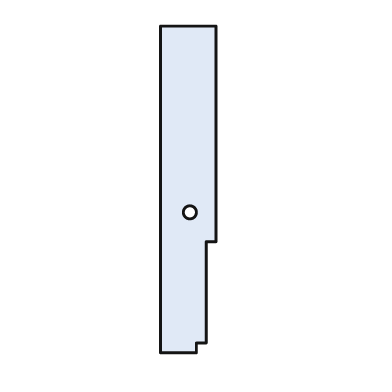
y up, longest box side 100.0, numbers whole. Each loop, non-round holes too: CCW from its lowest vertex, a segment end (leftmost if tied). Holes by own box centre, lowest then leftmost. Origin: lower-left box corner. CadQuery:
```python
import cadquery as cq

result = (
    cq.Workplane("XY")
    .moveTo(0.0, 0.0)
    .lineTo(11.0, 0.0)
    .lineTo(11.0, 3.0)
    .lineTo(14.0, 3.0)
    .lineTo(14.0, 34.0)
    .lineTo(17.0, 34.0)
    .lineTo(17.0, 100.0)
    .lineTo(0.0, 100.0)
    .close()
    .moveTo(9.0, 43.0)
    .circle(2.0)
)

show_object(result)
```